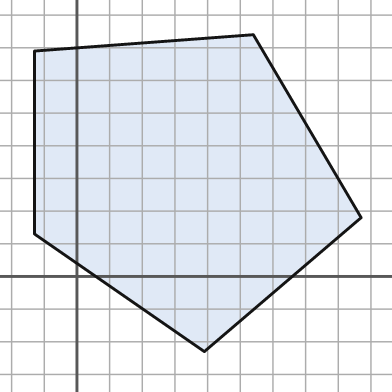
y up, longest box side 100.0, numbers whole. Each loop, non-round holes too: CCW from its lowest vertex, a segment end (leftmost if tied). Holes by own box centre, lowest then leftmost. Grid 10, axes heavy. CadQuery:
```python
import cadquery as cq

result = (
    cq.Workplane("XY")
    .moveTo(39.0, -23.0)
    .lineTo(87.0, 18.0)
    .lineTo(54.0, 74.0)
    .lineTo(-13.0, 69.0)
    .lineTo(-13.0, 13.0)
    .close()
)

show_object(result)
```